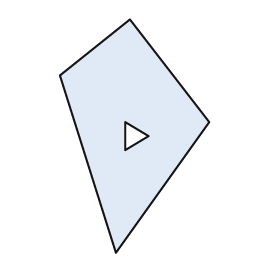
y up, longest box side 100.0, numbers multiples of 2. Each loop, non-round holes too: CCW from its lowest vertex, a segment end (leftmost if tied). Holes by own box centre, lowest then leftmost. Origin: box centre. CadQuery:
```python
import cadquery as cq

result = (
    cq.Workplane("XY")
    .moveTo(-8.0, -50.0)
    .lineTo(32.0, 6.0)
    .lineTo(-2.0, 50.0)
    .lineTo(-32.0, 26.0)
    .close()
    .moveTo(-4.0, -6.0)
    .lineTo(6.0, 0.0)
    .lineTo(-4.0, 6.0)
    .close()
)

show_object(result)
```